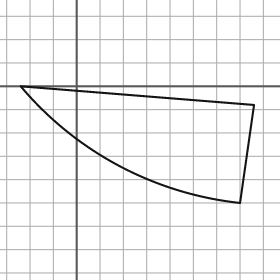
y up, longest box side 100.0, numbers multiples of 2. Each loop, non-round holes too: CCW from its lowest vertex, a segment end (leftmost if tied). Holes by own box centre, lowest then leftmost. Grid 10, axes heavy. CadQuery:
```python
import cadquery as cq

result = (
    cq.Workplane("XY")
    .moveTo(70.0, -50.0)
    .lineTo(76.0, -8.0)
    .lineTo(-24.0, 0.0)
    .threePointArc((18.0, -34.0), (70.0, -50.0))
    .close()
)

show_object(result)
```